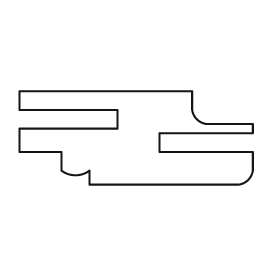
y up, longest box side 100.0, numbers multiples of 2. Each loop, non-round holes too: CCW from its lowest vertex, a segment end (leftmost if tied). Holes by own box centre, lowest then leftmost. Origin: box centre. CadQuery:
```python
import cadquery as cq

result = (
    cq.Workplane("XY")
    .moveTo(-20.0, -20.0)
    .lineTo(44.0, -20.0)
    .threePointArc((48.0, -18.0), (50.0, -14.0))
    .lineTo(50.0, -6.0)
    .lineTo(10.0, -6.0)
    .lineTo(10.0, 2.0)
    .lineTo(50.0, 2.0)
    .lineTo(50.0, 6.0)
    .lineTo(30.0, 6.0)
    .threePointArc((26.0, 8.0), (24.0, 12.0))
    .lineTo(24.0, 20.0)
    .lineTo(-50.0, 20.0)
    .lineTo(-50.0, 12.0)
    .lineTo(-8.0, 12.0)
    .lineTo(-8.0, 4.0)
    .lineTo(-50.0, 4.0)
    .lineTo(-50.0, -6.0)
    .lineTo(-32.0, -6.0)
    .lineTo(-32.0, -14.0)
    .threePointArc((-26.0, -16.0), (-20.0, -14.0))
    .close()
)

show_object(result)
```